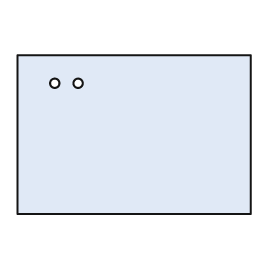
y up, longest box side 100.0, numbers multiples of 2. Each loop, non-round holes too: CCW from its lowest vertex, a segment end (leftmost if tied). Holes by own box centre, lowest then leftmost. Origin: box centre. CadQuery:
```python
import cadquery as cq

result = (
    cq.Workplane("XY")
    .moveTo(-50.0, -34.0)
    .lineTo(50.0, -34.0)
    .lineTo(50.0, 34.0)
    .lineTo(-50.0, 34.0)
    .close()
    .moveTo(-34.0, 22.0)
    .circle(2.0)
    .moveTo(-24.0, 22.0)
    .circle(2.0)
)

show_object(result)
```